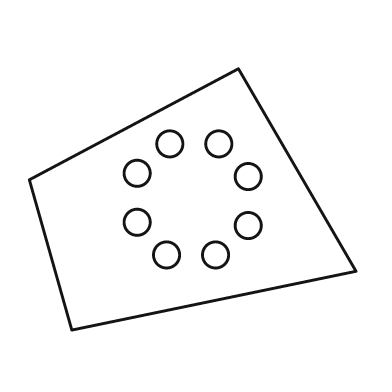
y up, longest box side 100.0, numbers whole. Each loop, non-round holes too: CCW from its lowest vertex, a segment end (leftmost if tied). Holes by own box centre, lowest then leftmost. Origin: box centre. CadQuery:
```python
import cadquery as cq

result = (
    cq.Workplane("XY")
    .moveTo(-37.0, -40.0)
    .lineTo(50.0, -22.0)
    .lineTo(14.0, 40.0)
    .lineTo(-50.0, 6.0)
    .close()
    .moveTo(-8.0, -17.0)
    .circle(4.0)
    .moveTo(7.0, -17.0)
    .circle(4.0)
    .moveTo(17.0, -8.0)
    .circle(4.0)
    .moveTo(-17.0, -7.0)
    .circle(4.0)
    .moveTo(17.0, 7.0)
    .circle(4.0)
    .moveTo(-17.0, 8.0)
    .circle(4.0)
    .moveTo(-7.0, 17.0)
    .circle(4.0)
    .moveTo(8.0, 17.0)
    .circle(4.0)
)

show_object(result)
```